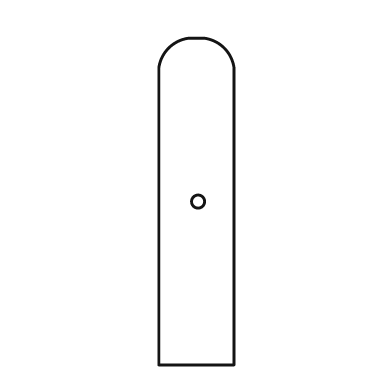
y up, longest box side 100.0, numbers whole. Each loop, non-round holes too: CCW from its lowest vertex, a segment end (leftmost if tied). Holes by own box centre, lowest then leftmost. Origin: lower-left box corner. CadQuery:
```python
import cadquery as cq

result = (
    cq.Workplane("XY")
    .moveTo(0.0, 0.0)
    .lineTo(23.0, 0.0)
    .lineTo(23.0, 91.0)
    .threePointArc((20.0, 97.0), (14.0, 100.0))
    .lineTo(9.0, 100.0)
    .threePointArc((3.0, 97.0), (0.0, 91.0))
    .close()
    .moveTo(12.0, 50.0)
    .circle(2.0)
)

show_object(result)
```